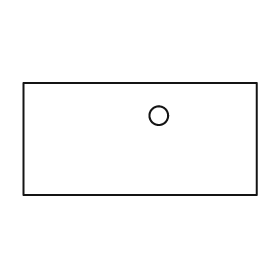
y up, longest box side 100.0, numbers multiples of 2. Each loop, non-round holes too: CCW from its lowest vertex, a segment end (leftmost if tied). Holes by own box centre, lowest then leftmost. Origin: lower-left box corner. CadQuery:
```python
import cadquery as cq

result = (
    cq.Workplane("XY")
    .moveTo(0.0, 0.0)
    .lineTo(100.0, 0.0)
    .lineTo(100.0, 48.0)
    .lineTo(0.0, 48.0)
    .close()
    .moveTo(58.0, 34.0)
    .circle(4.0)
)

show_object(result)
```